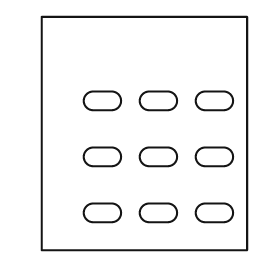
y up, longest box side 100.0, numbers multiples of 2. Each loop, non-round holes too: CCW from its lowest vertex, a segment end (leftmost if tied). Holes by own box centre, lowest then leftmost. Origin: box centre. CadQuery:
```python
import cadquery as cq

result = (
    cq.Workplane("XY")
    .moveTo(-44.0, -50.0)
    .lineTo(44.0, -50.0)
    .lineTo(44.0, 50.0)
    .lineTo(-44.0, 50.0)
    .close()
    .moveTo(-22.0, -38.0)
    .lineTo(-14.0, -38.0)
    .threePointArc((-10.0, -34.0), (-14.0, -30.0))
    .lineTo(-22.0, -30.0)
    .threePointArc((-26.0, -34.0), (-22.0, -38.0))
    .close()
    .moveTo(2.0, -38.0)
    .lineTo(10.0, -38.0)
    .threePointArc((14.0, -34.0), (10.0, -30.0))
    .lineTo(2.0, -30.0)
    .threePointArc((-2.0, -34.0), (2.0, -38.0))
    .close()
    .moveTo(26.0, -38.0)
    .lineTo(34.0, -38.0)
    .threePointArc((38.0, -34.0), (34.0, -30.0))
    .lineTo(26.0, -30.0)
    .threePointArc((22.0, -34.0), (26.0, -38.0))
    .close()
    .moveTo(-22.0, -14.0)
    .lineTo(-14.0, -14.0)
    .threePointArc((-10.0, -10.0), (-14.0, -6.0))
    .lineTo(-22.0, -6.0)
    .threePointArc((-26.0, -10.0), (-22.0, -14.0))
    .close()
    .moveTo(2.0, -14.0)
    .lineTo(10.0, -14.0)
    .threePointArc((14.0, -10.0), (10.0, -6.0))
    .lineTo(2.0, -6.0)
    .threePointArc((-2.0, -10.0), (2.0, -14.0))
    .close()
    .moveTo(26.0, -14.0)
    .lineTo(34.0, -14.0)
    .threePointArc((38.0, -10.0), (34.0, -6.0))
    .lineTo(26.0, -6.0)
    .threePointArc((22.0, -10.0), (26.0, -14.0))
    .close()
    .moveTo(-22.0, 10.0)
    .lineTo(-14.0, 10.0)
    .threePointArc((-10.0, 14.0), (-14.0, 18.0))
    .lineTo(-22.0, 18.0)
    .threePointArc((-26.0, 14.0), (-22.0, 10.0))
    .close()
    .moveTo(2.0, 10.0)
    .lineTo(10.0, 10.0)
    .threePointArc((14.0, 14.0), (10.0, 18.0))
    .lineTo(2.0, 18.0)
    .threePointArc((-2.0, 14.0), (2.0, 10.0))
    .close()
    .moveTo(26.0, 10.0)
    .lineTo(34.0, 10.0)
    .threePointArc((38.0, 14.0), (34.0, 18.0))
    .lineTo(26.0, 18.0)
    .threePointArc((22.0, 14.0), (26.0, 10.0))
    .close()
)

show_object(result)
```